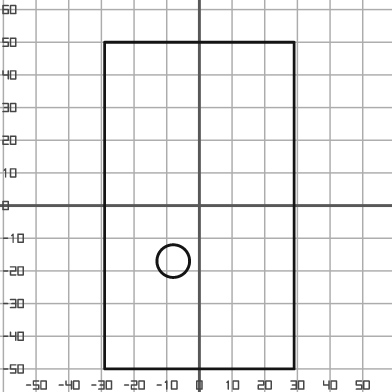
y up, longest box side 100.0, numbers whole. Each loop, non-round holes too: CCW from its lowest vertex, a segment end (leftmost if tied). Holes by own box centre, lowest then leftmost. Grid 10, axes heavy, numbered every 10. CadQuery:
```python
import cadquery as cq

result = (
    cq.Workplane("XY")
    .moveTo(-29.0, -50.0)
    .lineTo(29.0, -50.0)
    .lineTo(29.0, 50.0)
    .lineTo(-29.0, 50.0)
    .close()
    .moveTo(-8.0, -17.0)
    .circle(5.0)
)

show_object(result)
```